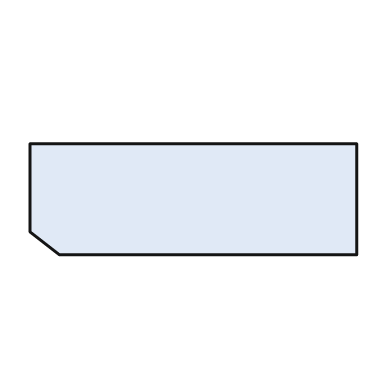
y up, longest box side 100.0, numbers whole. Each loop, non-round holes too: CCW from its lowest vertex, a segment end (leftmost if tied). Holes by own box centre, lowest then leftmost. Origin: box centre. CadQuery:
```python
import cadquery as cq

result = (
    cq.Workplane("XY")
    .moveTo(-41.0, -17.0)
    .lineTo(50.0, -17.0)
    .lineTo(50.0, 17.0)
    .lineTo(-50.0, 17.0)
    .lineTo(-50.0, -10.0)
    .close()
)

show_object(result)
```